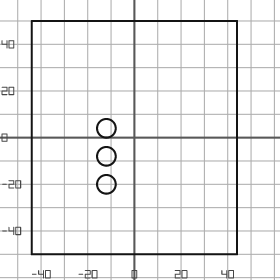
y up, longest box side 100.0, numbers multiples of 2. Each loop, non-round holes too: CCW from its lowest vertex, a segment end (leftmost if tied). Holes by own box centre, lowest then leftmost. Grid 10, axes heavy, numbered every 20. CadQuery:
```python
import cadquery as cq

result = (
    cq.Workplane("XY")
    .moveTo(-44.0, -50.0)
    .lineTo(44.0, -50.0)
    .lineTo(44.0, 50.0)
    .lineTo(-44.0, 50.0)
    .close()
    .moveTo(-12.0, -20.0)
    .circle(4.0)
    .moveTo(-12.0, -8.0)
    .circle(4.0)
    .moveTo(-12.0, 4.0)
    .circle(4.0)
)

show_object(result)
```